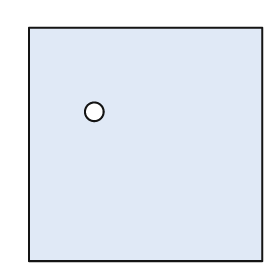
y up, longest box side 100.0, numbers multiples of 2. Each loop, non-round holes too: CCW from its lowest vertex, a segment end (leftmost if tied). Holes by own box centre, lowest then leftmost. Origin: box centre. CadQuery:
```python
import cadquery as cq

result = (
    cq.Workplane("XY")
    .moveTo(-50.0, -50.0)
    .lineTo(50.0, -50.0)
    .lineTo(50.0, 50.0)
    .lineTo(-50.0, 50.0)
    .close()
    .moveTo(-22.0, 14.0)
    .circle(4.0)
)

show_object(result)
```